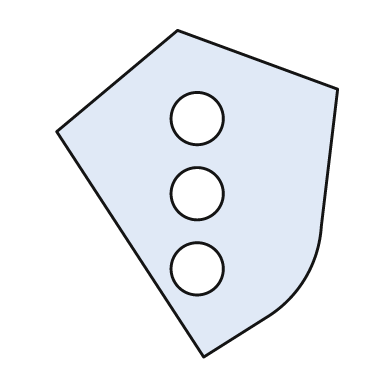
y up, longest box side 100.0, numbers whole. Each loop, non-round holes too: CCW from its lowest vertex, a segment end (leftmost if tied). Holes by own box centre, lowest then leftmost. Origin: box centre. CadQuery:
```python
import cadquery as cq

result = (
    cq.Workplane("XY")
    .moveTo(2.0, -50.0)
    .lineTo(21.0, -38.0)
    .threePointArc((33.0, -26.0), (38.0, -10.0))
    .lineTo(43.0, 32.0)
    .lineTo(-6.0, 50.0)
    .lineTo(-43.0, 19.0)
    .close()
    .moveTo(0.0, -23.0)
    .circle(8.0)
    .moveTo(0.0, 0.0)
    .circle(8.0)
    .moveTo(0.0, 23.0)
    .circle(8.0)
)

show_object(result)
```